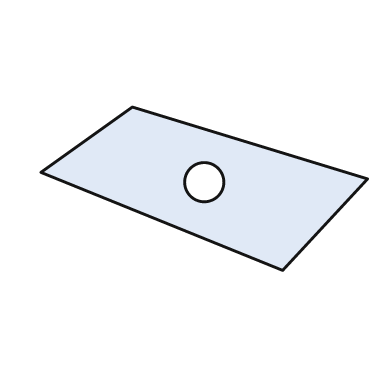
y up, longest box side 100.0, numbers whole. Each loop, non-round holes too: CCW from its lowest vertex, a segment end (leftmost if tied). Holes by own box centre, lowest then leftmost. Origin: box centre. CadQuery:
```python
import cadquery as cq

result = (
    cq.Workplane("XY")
    .moveTo(24.0, -25.0)
    .lineTo(50.0, 3.0)
    .lineTo(-22.0, 25.0)
    .lineTo(-50.0, 5.0)
    .close()
    .moveTo(0.0, 2.0)
    .circle(6.0)
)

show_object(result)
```